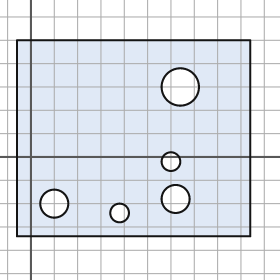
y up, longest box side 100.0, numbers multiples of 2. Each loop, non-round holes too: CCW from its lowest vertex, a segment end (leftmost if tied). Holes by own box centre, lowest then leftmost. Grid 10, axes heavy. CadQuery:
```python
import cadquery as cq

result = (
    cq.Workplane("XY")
    .moveTo(-6.0, -34.0)
    .lineTo(94.0, -34.0)
    .lineTo(94.0, 50.0)
    .lineTo(-6.0, 50.0)
    .close()
    .moveTo(38.0, -24.0)
    .circle(4.0)
    .moveTo(10.0, -20.0)
    .circle(6.0)
    .moveTo(62.0, -18.0)
    .circle(6.0)
    .moveTo(60.0, -2.0)
    .circle(4.0)
    .moveTo(64.0, 30.0)
    .circle(8.0)
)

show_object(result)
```